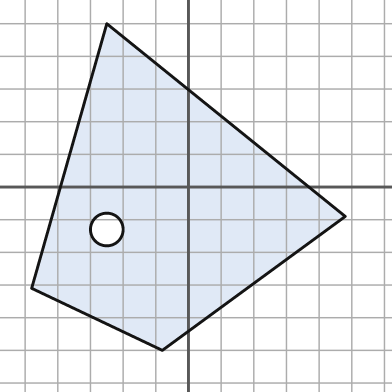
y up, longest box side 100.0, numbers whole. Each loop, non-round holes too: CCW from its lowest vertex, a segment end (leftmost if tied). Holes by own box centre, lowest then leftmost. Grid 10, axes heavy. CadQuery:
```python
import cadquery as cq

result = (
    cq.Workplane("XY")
    .moveTo(-8.0, -50.0)
    .lineTo(48.0, -9.0)
    .lineTo(-25.0, 50.0)
    .lineTo(-48.0, -31.0)
    .close()
    .moveTo(-25.0, -13.0)
    .circle(5.0)
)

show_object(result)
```